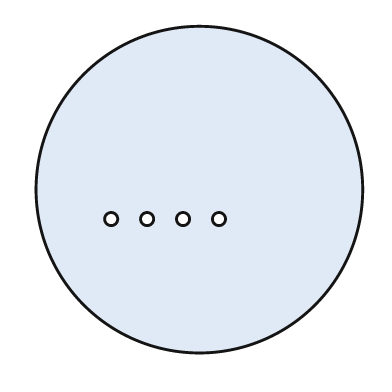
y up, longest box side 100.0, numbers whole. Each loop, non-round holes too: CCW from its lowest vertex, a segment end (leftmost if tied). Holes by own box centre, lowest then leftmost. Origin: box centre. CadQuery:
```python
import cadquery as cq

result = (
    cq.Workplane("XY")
    .moveTo(0.0, 0.0)
    .circle(50.0)
    .moveTo(-27.0, -9.0)
    .circle(2.0)
    .moveTo(-16.0, -9.0)
    .circle(2.0)
    .moveTo(-5.0, -9.0)
    .circle(2.0)
    .moveTo(6.0, -9.0)
    .circle(2.0)
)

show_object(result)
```